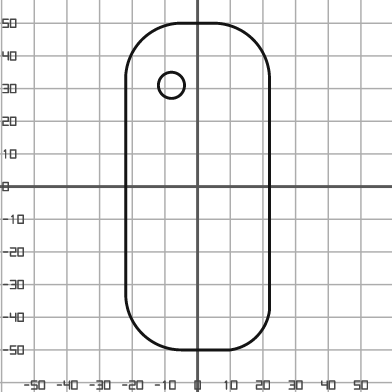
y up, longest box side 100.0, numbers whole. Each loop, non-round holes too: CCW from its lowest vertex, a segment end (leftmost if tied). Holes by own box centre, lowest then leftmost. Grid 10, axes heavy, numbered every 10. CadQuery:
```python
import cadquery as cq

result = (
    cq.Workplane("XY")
    .moveTo(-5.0, -50.0)
    .lineTo(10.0, -50.0)
    .threePointArc((18.0, -46.0), (22.0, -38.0))
    .lineTo(22.0, 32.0)
    .threePointArc((17.0, 45.0), (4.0, 50.0))
    .lineTo(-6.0, 50.0)
    .threePointArc((-17.0, 45.0), (-22.0, 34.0))
    .lineTo(-22.0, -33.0)
    .threePointArc((-17.0, -45.0), (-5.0, -50.0))
    .close()
    .moveTo(-8.0, 31.0)
    .circle(4.0)
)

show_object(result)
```